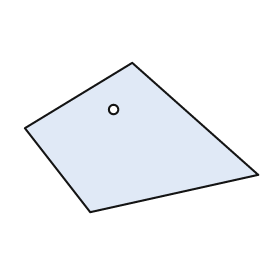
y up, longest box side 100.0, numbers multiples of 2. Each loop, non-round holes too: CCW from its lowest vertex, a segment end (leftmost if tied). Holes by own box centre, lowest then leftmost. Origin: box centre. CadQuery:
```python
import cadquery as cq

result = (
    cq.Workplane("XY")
    .moveTo(-22.0, -32.0)
    .lineTo(50.0, -16.0)
    .lineTo(-4.0, 32.0)
    .lineTo(-50.0, 4.0)
    .close()
    .moveTo(-12.0, 12.0)
    .circle(2.0)
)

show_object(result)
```